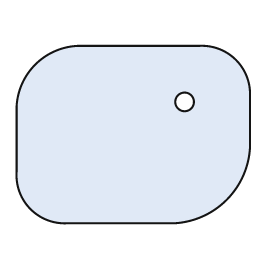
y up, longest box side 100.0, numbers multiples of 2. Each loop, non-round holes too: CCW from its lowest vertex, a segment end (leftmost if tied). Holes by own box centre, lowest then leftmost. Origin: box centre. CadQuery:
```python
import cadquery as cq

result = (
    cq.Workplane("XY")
    .moveTo(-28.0, -38.0)
    .lineTo(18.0, -38.0)
    .threePointArc((40.0, -28.0), (50.0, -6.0))
    .lineTo(50.0, 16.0)
    .threePointArc((44.0, 32.0), (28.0, 38.0))
    .lineTo(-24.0, 38.0)
    .threePointArc((-42.0, 30.0), (-50.0, 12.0))
    .lineTo(-50.0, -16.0)
    .threePointArc((-44.0, -32.0), (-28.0, -38.0))
    .close()
    .moveTo(22.0, 14.0)
    .circle(4.0)
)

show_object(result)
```